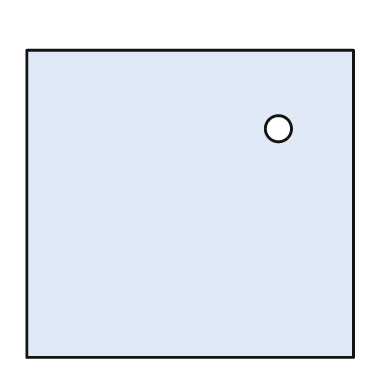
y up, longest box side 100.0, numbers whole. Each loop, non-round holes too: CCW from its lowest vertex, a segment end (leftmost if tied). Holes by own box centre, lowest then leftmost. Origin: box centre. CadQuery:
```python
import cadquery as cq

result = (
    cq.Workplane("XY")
    .moveTo(-50.0, -47.0)
    .lineTo(50.0, -47.0)
    .lineTo(50.0, 47.0)
    .lineTo(-50.0, 47.0)
    .close()
    .moveTo(27.0, 23.0)
    .circle(4.0)
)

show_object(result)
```